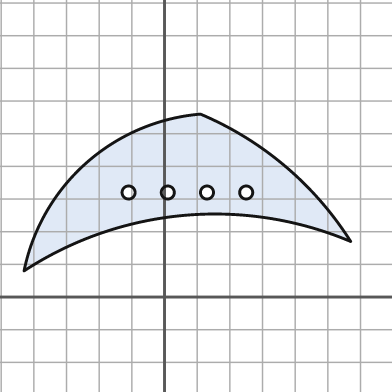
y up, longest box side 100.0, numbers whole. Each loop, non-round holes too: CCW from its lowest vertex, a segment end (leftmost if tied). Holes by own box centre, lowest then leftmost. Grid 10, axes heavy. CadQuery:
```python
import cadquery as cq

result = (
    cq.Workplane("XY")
    .moveTo(-43.0, 8.0)
    .threePointArc((6.0, 25.0), (57.0, 17.0))
    .threePointArc((37.0, 40.0), (11.0, 56.0))
    .threePointArc((-24.0, 41.0), (-43.0, 8.0))
    .close()
    .moveTo(-11.0, 32.0)
    .circle(2.0)
    .moveTo(1.0, 32.0)
    .circle(2.0)
    .moveTo(13.0, 32.0)
    .circle(2.0)
    .moveTo(25.0, 32.0)
    .circle(2.0)
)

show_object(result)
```